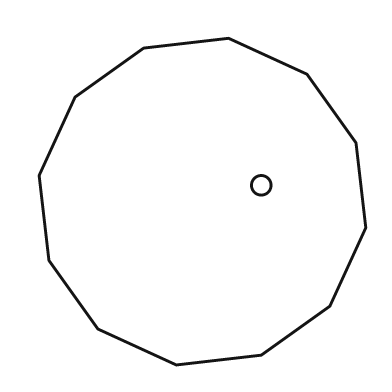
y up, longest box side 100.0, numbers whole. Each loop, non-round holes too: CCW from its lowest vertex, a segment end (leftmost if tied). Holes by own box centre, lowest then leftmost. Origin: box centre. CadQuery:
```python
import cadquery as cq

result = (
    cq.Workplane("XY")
    .moveTo(-8.0, -50.0)
    .lineTo(18.0, -47.0)
    .lineTo(39.0, -32.0)
    .lineTo(50.0, -8.0)
    .lineTo(47.0, 18.0)
    .lineTo(32.0, 39.0)
    .lineTo(8.0, 50.0)
    .lineTo(-18.0, 47.0)
    .lineTo(-39.0, 32.0)
    .lineTo(-50.0, 8.0)
    .lineTo(-47.0, -18.0)
    .lineTo(-32.0, -39.0)
    .close()
    .moveTo(18.0, 5.0)
    .circle(3.0)
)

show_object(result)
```